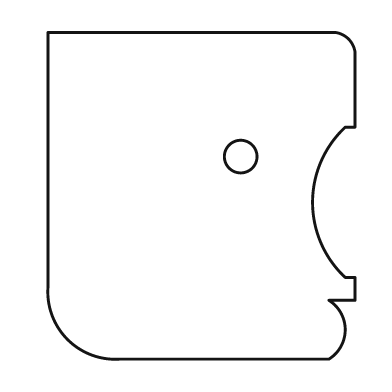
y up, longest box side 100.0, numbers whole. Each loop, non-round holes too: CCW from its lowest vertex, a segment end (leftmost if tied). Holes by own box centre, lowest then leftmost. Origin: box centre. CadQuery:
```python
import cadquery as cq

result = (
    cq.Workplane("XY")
    .moveTo(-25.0, -50.0)
    .lineTo(39.0, -50.0)
    .threePointArc((44.0, -41.0), (39.0, -32.0))
    .lineTo(47.0, -32.0)
    .lineTo(47.0, -25.0)
    .lineTo(44.0, -25.0)
    .threePointArc((34.0, -2.0), (44.0, 21.0))
    .lineTo(47.0, 21.0)
    .lineTo(47.0, 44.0)
    .threePointArc((45.0, 48.0), (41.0, 50.0))
    .lineTo(-47.0, 50.0)
    .lineTo(-47.0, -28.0)
    .threePointArc((-41.0, -44.0), (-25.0, -50.0))
    .close()
    .moveTo(12.0, 12.0)
    .circle(5.0)
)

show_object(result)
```